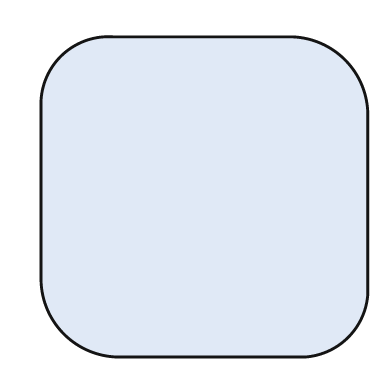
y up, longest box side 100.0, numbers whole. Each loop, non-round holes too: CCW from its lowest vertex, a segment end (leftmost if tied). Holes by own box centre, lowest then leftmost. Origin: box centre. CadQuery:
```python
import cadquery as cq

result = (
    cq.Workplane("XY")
    .moveTo(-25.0, -49.0)
    .lineTo(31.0, -49.0)
    .threePointArc((44.0, -43.0), (50.0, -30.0))
    .lineTo(50.0, 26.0)
    .threePointArc((43.0, 42.0), (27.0, 49.0))
    .lineTo(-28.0, 49.0)
    .threePointArc((-44.0, 43.0), (-50.0, 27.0))
    .lineTo(-50.0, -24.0)
    .threePointArc((-43.0, -42.0), (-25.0, -49.0))
    .close()
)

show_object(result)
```